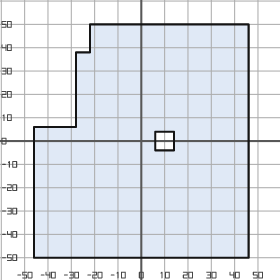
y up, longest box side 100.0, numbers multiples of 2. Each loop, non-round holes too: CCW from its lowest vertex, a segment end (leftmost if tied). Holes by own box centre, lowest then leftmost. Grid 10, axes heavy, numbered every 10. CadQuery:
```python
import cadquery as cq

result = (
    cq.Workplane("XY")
    .moveTo(-46.0, -50.0)
    .lineTo(46.0, -50.0)
    .lineTo(46.0, 50.0)
    .lineTo(-22.0, 50.0)
    .lineTo(-22.0, 38.0)
    .lineTo(-28.0, 38.0)
    .lineTo(-28.0, 6.0)
    .lineTo(-46.0, 6.0)
    .close()
    .moveTo(6.0, -4.0)
    .lineTo(14.0, -4.0)
    .lineTo(14.0, 4.0)
    .lineTo(6.0, 4.0)
    .close()
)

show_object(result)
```